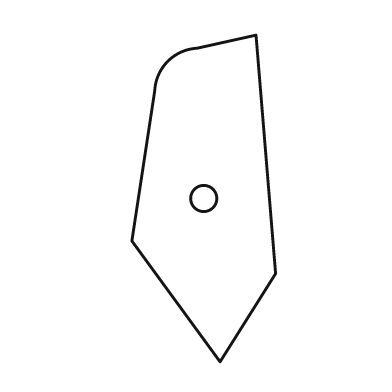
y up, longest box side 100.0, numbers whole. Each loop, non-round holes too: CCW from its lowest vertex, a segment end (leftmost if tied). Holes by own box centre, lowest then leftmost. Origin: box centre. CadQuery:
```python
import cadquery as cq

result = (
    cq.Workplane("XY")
    .moveTo(5.0, -50.0)
    .lineTo(22.0, -23.0)
    .lineTo(16.0, 50.0)
    .lineTo(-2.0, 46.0)
    .threePointArc((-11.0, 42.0), (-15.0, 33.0))
    .lineTo(-22.0, -13.0)
    .close()
    .moveTo(0.0, 0.0)
    .circle(4.0)
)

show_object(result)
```